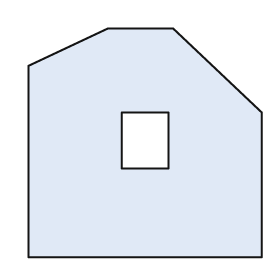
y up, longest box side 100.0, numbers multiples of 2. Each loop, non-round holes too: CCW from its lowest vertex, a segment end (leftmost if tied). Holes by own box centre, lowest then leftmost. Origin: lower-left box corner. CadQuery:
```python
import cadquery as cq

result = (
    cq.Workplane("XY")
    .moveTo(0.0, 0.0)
    .lineTo(100.0, 0.0)
    .lineTo(100.0, 62.0)
    .lineTo(62.0, 98.0)
    .lineTo(34.0, 98.0)
    .lineTo(0.0, 82.0)
    .close()
    .moveTo(40.0, 38.0)
    .lineTo(60.0, 38.0)
    .lineTo(60.0, 62.0)
    .lineTo(40.0, 62.0)
    .close()
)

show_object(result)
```